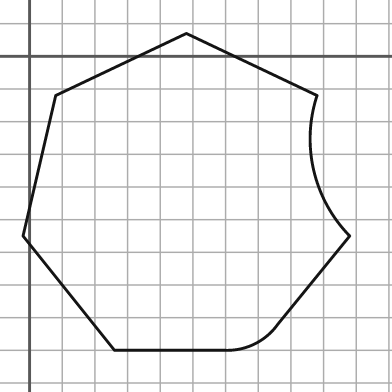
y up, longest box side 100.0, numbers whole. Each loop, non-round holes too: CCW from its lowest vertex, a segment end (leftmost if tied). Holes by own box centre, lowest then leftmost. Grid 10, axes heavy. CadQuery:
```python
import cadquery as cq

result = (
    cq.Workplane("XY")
    .moveTo(26.0, -90.0)
    .lineTo(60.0, -90.0)
    .threePointArc((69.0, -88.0), (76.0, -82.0))
    .lineTo(98.0, -55.0)
    .threePointArc((87.0, -35.0), (88.0, -12.0))
    .lineTo(48.0, 7.0)
    .lineTo(8.0, -12.0)
    .lineTo(-2.0, -55.0)
    .close()
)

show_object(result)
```